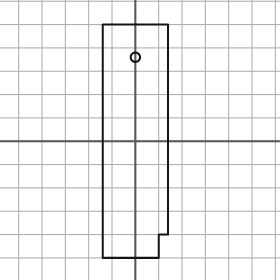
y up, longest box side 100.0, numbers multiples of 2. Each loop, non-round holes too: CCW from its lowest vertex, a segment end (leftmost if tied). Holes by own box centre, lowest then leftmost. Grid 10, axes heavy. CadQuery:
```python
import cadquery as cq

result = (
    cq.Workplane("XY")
    .moveTo(-14.0, -50.0)
    .lineTo(10.0, -50.0)
    .lineTo(10.0, -40.0)
    .lineTo(14.0, -40.0)
    .lineTo(14.0, 50.0)
    .lineTo(-14.0, 50.0)
    .close()
    .moveTo(0.0, 36.0)
    .circle(2.0)
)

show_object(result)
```